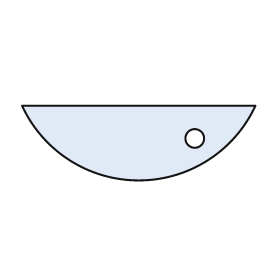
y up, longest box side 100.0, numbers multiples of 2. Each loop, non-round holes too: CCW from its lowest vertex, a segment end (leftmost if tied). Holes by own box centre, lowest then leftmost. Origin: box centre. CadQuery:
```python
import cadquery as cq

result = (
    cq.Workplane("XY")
    .moveTo(-50.0, 16.0)
    .threePointArc((0.0, -16.0), (50.0, 16.0))
    .close()
    .moveTo(24.0, 2.0)
    .circle(4.0)
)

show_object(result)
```